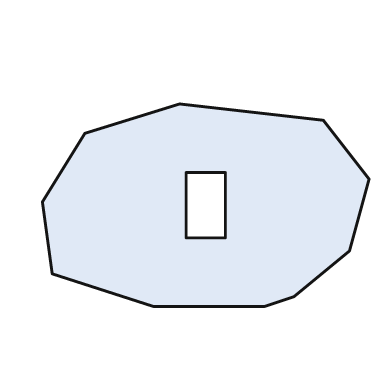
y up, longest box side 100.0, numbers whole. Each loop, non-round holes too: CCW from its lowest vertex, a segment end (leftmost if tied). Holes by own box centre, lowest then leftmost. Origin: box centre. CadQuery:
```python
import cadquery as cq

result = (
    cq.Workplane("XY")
    .moveTo(-16.0, -31.0)
    .lineTo(18.0, -31.0)
    .lineTo(27.0, -28.0)
    .lineTo(44.0, -14.0)
    .lineTo(50.0, 8.0)
    .lineTo(36.0, 26.0)
    .lineTo(-8.0, 31.0)
    .lineTo(-37.0, 22.0)
    .lineTo(-50.0, 1.0)
    .lineTo(-47.0, -21.0)
    .close()
    .moveTo(-6.0, -10.0)
    .lineTo(6.0, -10.0)
    .lineTo(6.0, 10.0)
    .lineTo(-6.0, 10.0)
    .close()
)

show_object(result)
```